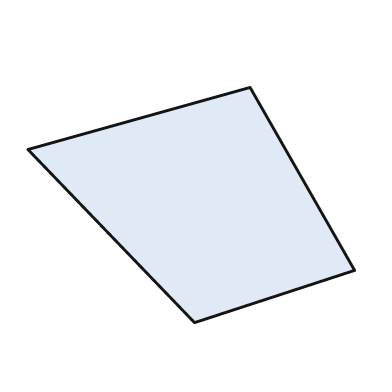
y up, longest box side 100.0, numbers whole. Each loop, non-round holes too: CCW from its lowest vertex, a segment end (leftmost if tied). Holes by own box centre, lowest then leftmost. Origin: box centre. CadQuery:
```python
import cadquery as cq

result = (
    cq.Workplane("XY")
    .moveTo(1.0, -36.0)
    .lineTo(50.0, -20.0)
    .lineTo(18.0, 36.0)
    .lineTo(-50.0, 17.0)
    .close()
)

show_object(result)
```